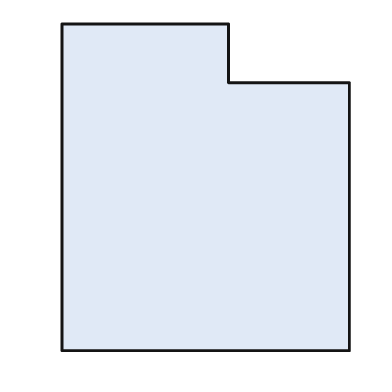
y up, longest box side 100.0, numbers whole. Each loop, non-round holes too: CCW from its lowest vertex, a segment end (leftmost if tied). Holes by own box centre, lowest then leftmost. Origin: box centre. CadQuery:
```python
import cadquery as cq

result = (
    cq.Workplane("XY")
    .moveTo(-44.0, -50.0)
    .lineTo(44.0, -50.0)
    .lineTo(44.0, 32.0)
    .lineTo(7.0, 32.0)
    .lineTo(7.0, 50.0)
    .lineTo(-44.0, 50.0)
    .close()
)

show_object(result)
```